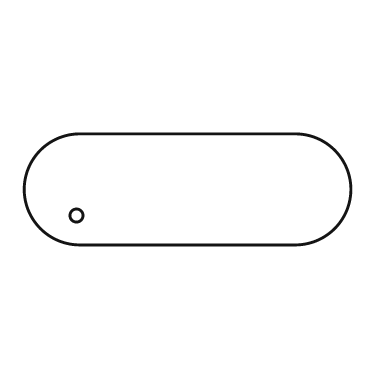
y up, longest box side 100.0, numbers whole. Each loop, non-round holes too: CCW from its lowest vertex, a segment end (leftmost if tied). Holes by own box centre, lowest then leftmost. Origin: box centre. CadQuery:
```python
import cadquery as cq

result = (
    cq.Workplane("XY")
    .moveTo(-33.0, -17.0)
    .lineTo(33.0, -17.0)
    .threePointArc((50.0, 0.0), (33.0, 17.0))
    .lineTo(-33.0, 17.0)
    .threePointArc((-50.0, 0.0), (-33.0, -17.0))
    .close()
    .moveTo(-34.0, -8.0)
    .circle(2.0)
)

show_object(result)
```